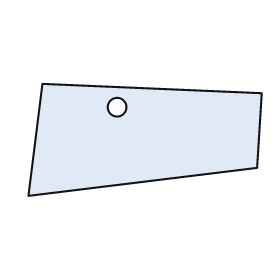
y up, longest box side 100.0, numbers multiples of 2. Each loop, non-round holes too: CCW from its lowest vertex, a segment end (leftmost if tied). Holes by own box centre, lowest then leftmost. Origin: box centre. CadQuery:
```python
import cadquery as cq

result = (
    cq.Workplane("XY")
    .moveTo(-50.0, -24.0)
    .lineTo(48.0, -12.0)
    .lineTo(50.0, 20.0)
    .lineTo(-44.0, 24.0)
    .close()
    .moveTo(-12.0, 14.0)
    .circle(4.0)
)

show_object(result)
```